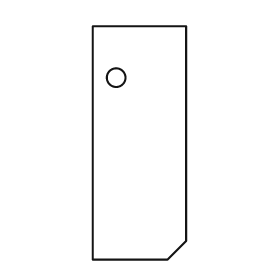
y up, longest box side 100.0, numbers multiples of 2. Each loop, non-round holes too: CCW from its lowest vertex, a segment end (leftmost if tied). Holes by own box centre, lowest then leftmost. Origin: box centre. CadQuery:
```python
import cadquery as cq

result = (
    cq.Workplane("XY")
    .moveTo(-20.0, -50.0)
    .lineTo(12.0, -50.0)
    .lineTo(20.0, -42.0)
    .lineTo(20.0, 50.0)
    .lineTo(-20.0, 50.0)
    .close()
    .moveTo(-10.0, 28.0)
    .circle(4.0)
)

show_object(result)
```